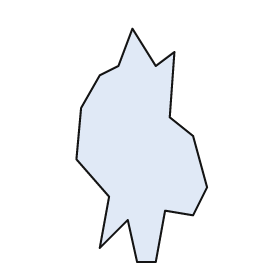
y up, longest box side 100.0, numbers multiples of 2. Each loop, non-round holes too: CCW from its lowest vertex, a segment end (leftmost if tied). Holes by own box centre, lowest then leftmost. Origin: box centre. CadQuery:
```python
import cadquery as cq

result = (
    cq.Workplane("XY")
    .moveTo(-2.0, -50.0)
    .lineTo(6.0, -50.0)
    .lineTo(10.0, -28.0)
    .lineTo(22.0, -30.0)
    .lineTo(28.0, -18.0)
    .lineTo(22.0, 4.0)
    .lineTo(12.0, 12.0)
    .lineTo(14.0, 40.0)
    .lineTo(6.0, 34.0)
    .lineTo(-4.0, 50.0)
    .lineTo(-10.0, 34.0)
    .lineTo(-18.0, 30.0)
    .lineTo(-26.0, 16.0)
    .lineTo(-28.0, -6.0)
    .lineTo(-14.0, -22.0)
    .lineTo(-18.0, -44.0)
    .lineTo(-6.0, -32.0)
    .close()
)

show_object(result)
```